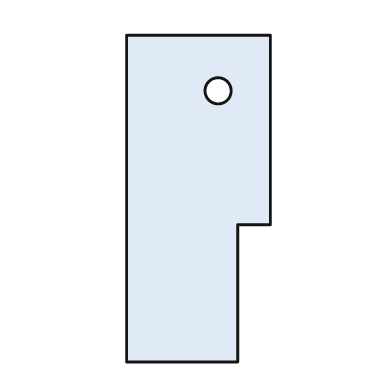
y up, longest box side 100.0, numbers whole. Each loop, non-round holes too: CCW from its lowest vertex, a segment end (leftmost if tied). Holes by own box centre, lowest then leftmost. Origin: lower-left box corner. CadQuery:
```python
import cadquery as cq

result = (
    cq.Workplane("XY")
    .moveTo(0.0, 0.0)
    .lineTo(34.0, 0.0)
    .lineTo(34.0, 42.0)
    .lineTo(44.0, 42.0)
    .lineTo(44.0, 100.0)
    .lineTo(0.0, 100.0)
    .close()
    .moveTo(28.0, 83.0)
    .circle(4.0)
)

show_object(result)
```